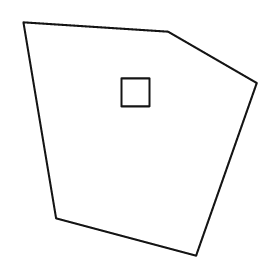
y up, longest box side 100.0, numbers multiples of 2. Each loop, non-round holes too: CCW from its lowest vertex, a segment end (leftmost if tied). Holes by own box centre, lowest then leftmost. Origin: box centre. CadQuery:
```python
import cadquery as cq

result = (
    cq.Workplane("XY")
    .moveTo(24.0, -50.0)
    .lineTo(50.0, 24.0)
    .lineTo(12.0, 46.0)
    .lineTo(-50.0, 50.0)
    .lineTo(-36.0, -34.0)
    .close()
    .moveTo(-8.0, 14.0)
    .lineTo(4.0, 14.0)
    .lineTo(4.0, 26.0)
    .lineTo(-8.0, 26.0)
    .close()
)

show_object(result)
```